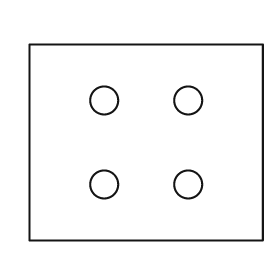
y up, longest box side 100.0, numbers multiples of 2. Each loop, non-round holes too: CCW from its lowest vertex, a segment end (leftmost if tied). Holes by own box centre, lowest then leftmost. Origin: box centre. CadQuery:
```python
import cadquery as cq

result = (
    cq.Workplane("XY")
    .moveTo(-50.0, -42.0)
    .lineTo(50.0, -42.0)
    .lineTo(50.0, 42.0)
    .lineTo(-50.0, 42.0)
    .close()
    .moveTo(-18.0, -18.0)
    .circle(6.0)
    .moveTo(18.0, -18.0)
    .circle(6.0)
    .moveTo(-18.0, 18.0)
    .circle(6.0)
    .moveTo(18.0, 18.0)
    .circle(6.0)
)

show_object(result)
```